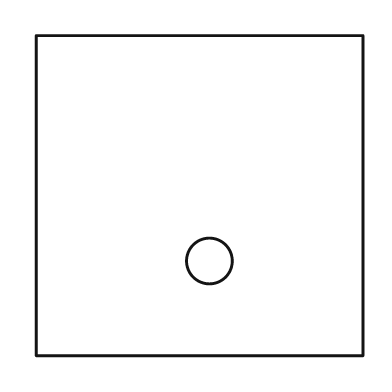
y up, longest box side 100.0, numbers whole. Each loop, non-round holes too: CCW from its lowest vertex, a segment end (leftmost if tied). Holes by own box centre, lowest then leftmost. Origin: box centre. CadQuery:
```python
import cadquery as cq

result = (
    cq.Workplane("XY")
    .moveTo(-50.0, -49.0)
    .lineTo(50.0, -49.0)
    .lineTo(50.0, 49.0)
    .lineTo(-50.0, 49.0)
    .close()
    .moveTo(3.0, -20.0)
    .circle(7.0)
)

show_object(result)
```